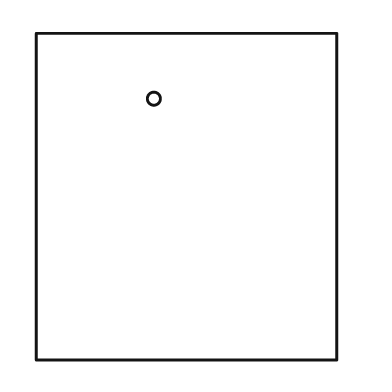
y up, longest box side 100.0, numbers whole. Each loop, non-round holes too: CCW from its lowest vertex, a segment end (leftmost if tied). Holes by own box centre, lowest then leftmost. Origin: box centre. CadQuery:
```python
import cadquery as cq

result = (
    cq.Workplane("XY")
    .moveTo(-46.0, -50.0)
    .lineTo(46.0, -50.0)
    .lineTo(46.0, 50.0)
    .lineTo(-46.0, 50.0)
    .close()
    .moveTo(-10.0, 30.0)
    .circle(2.0)
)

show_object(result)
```